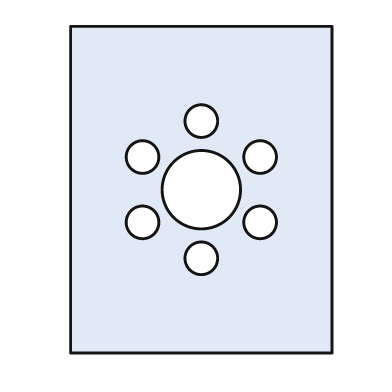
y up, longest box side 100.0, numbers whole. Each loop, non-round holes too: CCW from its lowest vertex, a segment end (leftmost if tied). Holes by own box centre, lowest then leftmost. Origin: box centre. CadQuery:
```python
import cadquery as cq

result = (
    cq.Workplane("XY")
    .moveTo(-40.0, -50.0)
    .lineTo(40.0, -50.0)
    .lineTo(40.0, 50.0)
    .lineTo(-40.0, 50.0)
    .close()
    .moveTo(0.0, -21.0)
    .circle(5.0)
    .moveTo(-18.0, -10.0)
    .circle(5.0)
    .moveTo(18.0, -10.0)
    .circle(5.0)
    .moveTo(0.0, 0.0)
    .circle(12.0)
    .moveTo(-18.0, 10.0)
    .circle(5.0)
    .moveTo(18.0, 10.0)
    .circle(5.0)
    .moveTo(0.0, 21.0)
    .circle(5.0)
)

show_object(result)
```